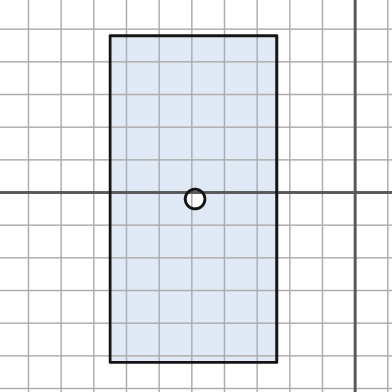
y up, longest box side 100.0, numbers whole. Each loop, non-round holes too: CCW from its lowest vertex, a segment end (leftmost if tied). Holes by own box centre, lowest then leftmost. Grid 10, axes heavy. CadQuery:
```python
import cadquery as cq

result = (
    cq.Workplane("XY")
    .moveTo(-75.0, -52.0)
    .lineTo(-24.0, -52.0)
    .lineTo(-24.0, 48.0)
    .lineTo(-75.0, 48.0)
    .close()
    .moveTo(-49.0, -2.0)
    .circle(3.0)
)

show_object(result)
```